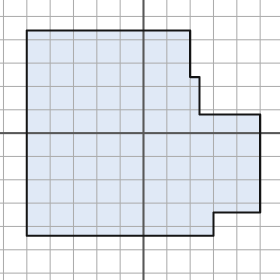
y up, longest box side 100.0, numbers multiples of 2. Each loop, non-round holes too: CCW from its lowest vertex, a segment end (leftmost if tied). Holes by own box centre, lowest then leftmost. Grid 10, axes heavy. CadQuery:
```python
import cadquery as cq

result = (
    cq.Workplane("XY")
    .moveTo(-50.0, -44.0)
    .lineTo(30.0, -44.0)
    .lineTo(30.0, -34.0)
    .lineTo(50.0, -34.0)
    .lineTo(50.0, 8.0)
    .lineTo(24.0, 8.0)
    .lineTo(24.0, 24.0)
    .lineTo(20.0, 24.0)
    .lineTo(20.0, 44.0)
    .lineTo(-50.0, 44.0)
    .close()
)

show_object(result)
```